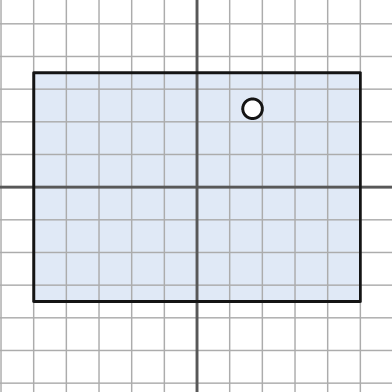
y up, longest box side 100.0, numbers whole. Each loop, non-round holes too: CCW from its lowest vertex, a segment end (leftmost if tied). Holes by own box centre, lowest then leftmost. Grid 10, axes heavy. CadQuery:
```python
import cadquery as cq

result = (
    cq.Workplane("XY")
    .moveTo(-50.0, -35.0)
    .lineTo(50.0, -35.0)
    .lineTo(50.0, 35.0)
    .lineTo(-50.0, 35.0)
    .close()
    .moveTo(17.0, 24.0)
    .circle(3.0)
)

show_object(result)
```